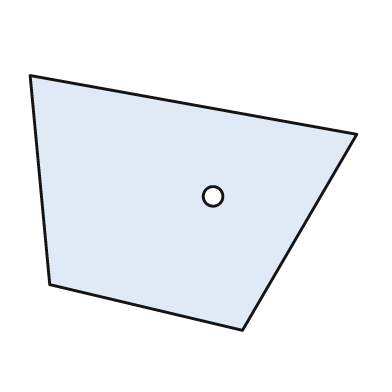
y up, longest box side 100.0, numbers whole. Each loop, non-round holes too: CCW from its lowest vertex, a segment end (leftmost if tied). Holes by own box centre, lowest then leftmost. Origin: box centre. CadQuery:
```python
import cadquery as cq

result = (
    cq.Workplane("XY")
    .moveTo(15.0, -39.0)
    .lineTo(50.0, 21.0)
    .lineTo(-50.0, 39.0)
    .lineTo(-44.0, -25.0)
    .close()
    .moveTo(6.0, 2.0)
    .circle(3.0)
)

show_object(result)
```